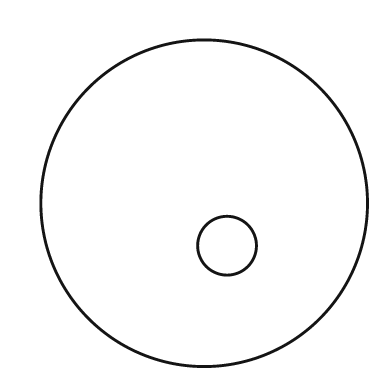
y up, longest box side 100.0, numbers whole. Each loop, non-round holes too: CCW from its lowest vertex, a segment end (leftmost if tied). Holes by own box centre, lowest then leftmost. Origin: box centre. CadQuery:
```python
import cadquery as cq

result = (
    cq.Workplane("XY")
    .moveTo(0.0, 0.0)
    .circle(50.0)
    .moveTo(7.0, -13.0)
    .circle(9.0)
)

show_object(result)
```